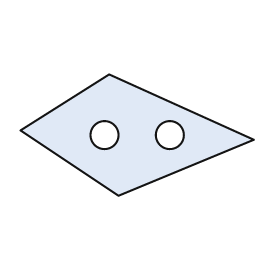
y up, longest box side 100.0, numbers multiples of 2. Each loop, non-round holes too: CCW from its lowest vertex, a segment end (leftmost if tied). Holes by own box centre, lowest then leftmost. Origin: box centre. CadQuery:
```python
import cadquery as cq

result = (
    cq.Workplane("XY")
    .moveTo(-8.0, -26.0)
    .lineTo(50.0, -2.0)
    .lineTo(-12.0, 26.0)
    .lineTo(-50.0, 2.0)
    .close()
    .moveTo(-14.0, 0.0)
    .circle(6.0)
    .moveTo(14.0, 0.0)
    .circle(6.0)
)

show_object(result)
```